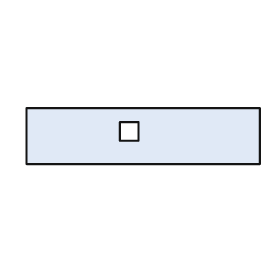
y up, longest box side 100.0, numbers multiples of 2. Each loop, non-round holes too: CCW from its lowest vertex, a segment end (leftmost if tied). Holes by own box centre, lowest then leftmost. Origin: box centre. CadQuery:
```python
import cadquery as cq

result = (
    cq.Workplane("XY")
    .moveTo(-50.0, -12.0)
    .lineTo(50.0, -12.0)
    .lineTo(50.0, 12.0)
    .lineTo(-50.0, 12.0)
    .close()
    .moveTo(-10.0, -2.0)
    .lineTo(-2.0, -2.0)
    .lineTo(-2.0, 6.0)
    .lineTo(-10.0, 6.0)
    .close()
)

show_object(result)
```